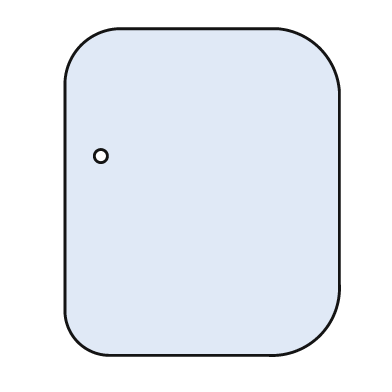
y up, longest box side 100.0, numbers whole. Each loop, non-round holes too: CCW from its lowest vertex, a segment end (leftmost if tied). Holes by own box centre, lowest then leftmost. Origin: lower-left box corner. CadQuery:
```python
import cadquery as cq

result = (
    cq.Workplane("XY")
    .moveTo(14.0, 0.0)
    .lineTo(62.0, 0.0)
    .threePointArc((78.0, 6.0), (84.0, 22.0))
    .lineTo(84.0, 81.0)
    .threePointArc((78.0, 94.0), (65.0, 100.0))
    .lineTo(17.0, 100.0)
    .threePointArc((5.0, 95.0), (0.0, 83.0))
    .lineTo(0.0, 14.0)
    .threePointArc((4.0, 4.0), (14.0, 0.0))
    .close()
    .moveTo(11.0, 61.0)
    .circle(2.0)
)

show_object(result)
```